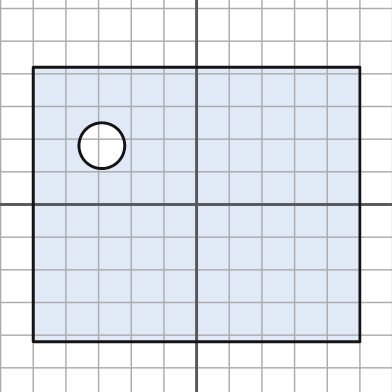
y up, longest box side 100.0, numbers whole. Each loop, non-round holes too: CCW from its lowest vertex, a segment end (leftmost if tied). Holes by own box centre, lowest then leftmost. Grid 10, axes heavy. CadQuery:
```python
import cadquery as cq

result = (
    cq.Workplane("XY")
    .moveTo(-50.0, -42.0)
    .lineTo(50.0, -42.0)
    .lineTo(50.0, 42.0)
    .lineTo(-50.0, 42.0)
    .close()
    .moveTo(-29.0, 18.0)
    .circle(7.0)
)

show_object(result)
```